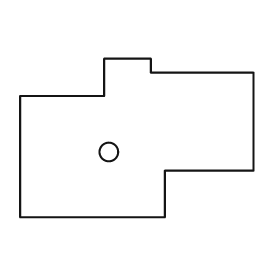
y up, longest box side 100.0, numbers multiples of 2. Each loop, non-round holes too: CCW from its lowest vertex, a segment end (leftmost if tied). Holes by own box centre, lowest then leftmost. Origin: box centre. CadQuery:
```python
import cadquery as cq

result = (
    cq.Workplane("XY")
    .moveTo(-50.0, -34.0)
    .lineTo(12.0, -34.0)
    .lineTo(12.0, -14.0)
    .lineTo(50.0, -14.0)
    .lineTo(50.0, 28.0)
    .lineTo(6.0, 28.0)
    .lineTo(6.0, 34.0)
    .lineTo(-14.0, 34.0)
    .lineTo(-14.0, 18.0)
    .lineTo(-50.0, 18.0)
    .close()
    .moveTo(-12.0, -6.0)
    .circle(4.0)
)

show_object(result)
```